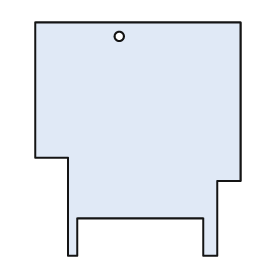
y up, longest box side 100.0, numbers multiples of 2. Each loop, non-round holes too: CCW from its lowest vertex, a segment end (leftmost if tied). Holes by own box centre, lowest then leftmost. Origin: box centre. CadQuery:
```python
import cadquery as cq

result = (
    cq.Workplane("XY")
    .moveTo(-30.0, -50.0)
    .lineTo(-26.0, -50.0)
    .lineTo(-26.0, -34.0)
    .lineTo(28.0, -34.0)
    .lineTo(28.0, -50.0)
    .lineTo(34.0, -50.0)
    .lineTo(34.0, -18.0)
    .lineTo(44.0, -18.0)
    .lineTo(44.0, 50.0)
    .lineTo(-44.0, 50.0)
    .lineTo(-44.0, -8.0)
    .lineTo(-30.0, -8.0)
    .close()
    .moveTo(-8.0, 44.0)
    .circle(2.0)
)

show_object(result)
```